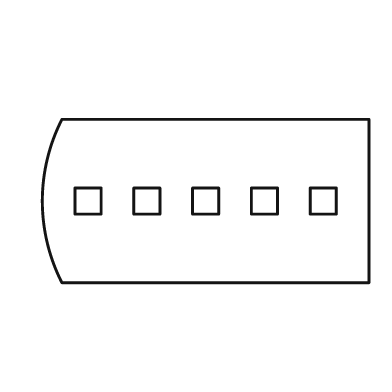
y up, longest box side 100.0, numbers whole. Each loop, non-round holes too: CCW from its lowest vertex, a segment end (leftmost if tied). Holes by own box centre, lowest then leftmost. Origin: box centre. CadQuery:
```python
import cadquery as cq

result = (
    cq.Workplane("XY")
    .moveTo(-44.0, -25.0)
    .lineTo(50.0, -25.0)
    .lineTo(50.0, 25.0)
    .lineTo(-44.0, 25.0)
    .threePointArc((-50.0, 0.0), (-44.0, -25.0))
    .close()
    .moveTo(-40.0, -4.0)
    .lineTo(-32.0, -4.0)
    .lineTo(-32.0, 4.0)
    .lineTo(-40.0, 4.0)
    .close()
    .moveTo(-22.0, -4.0)
    .lineTo(-14.0, -4.0)
    .lineTo(-14.0, 4.0)
    .lineTo(-22.0, 4.0)
    .close()
    .moveTo(-4.0, -4.0)
    .lineTo(4.0, -4.0)
    .lineTo(4.0, 4.0)
    .lineTo(-4.0, 4.0)
    .close()
    .moveTo(14.0, -4.0)
    .lineTo(22.0, -4.0)
    .lineTo(22.0, 4.0)
    .lineTo(14.0, 4.0)
    .close()
    .moveTo(32.0, -4.0)
    .lineTo(40.0, -4.0)
    .lineTo(40.0, 4.0)
    .lineTo(32.0, 4.0)
    .close()
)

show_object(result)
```